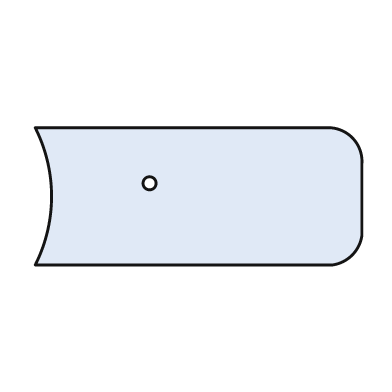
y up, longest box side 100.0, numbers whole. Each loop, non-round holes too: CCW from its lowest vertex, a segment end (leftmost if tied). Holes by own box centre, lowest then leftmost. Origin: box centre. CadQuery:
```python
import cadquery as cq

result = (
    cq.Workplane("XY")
    .moveTo(-50.0, -21.0)
    .lineTo(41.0, -21.0)
    .threePointArc((47.0, -18.0), (50.0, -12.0))
    .lineTo(50.0, 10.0)
    .threePointArc((47.0, 18.0), (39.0, 21.0))
    .lineTo(-50.0, 21.0)
    .threePointArc((-45.0, 0.0), (-50.0, -21.0))
    .close()
    .moveTo(-15.0, 4.0)
    .circle(2.0)
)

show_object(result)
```